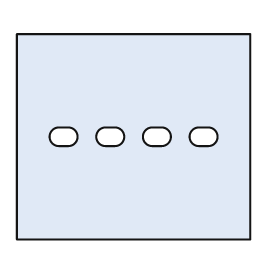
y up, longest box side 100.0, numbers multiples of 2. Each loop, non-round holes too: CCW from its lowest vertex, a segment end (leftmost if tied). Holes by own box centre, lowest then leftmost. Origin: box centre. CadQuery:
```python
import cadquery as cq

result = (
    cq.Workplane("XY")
    .moveTo(-50.0, -44.0)
    .lineTo(50.0, -44.0)
    .lineTo(50.0, 44.0)
    .lineTo(-50.0, 44.0)
    .close()
    .moveTo(-32.0, -4.0)
    .lineTo(-28.0, -4.0)
    .threePointArc((-24.0, 0.0), (-28.0, 4.0))
    .lineTo(-32.0, 4.0)
    .threePointArc((-36.0, 0.0), (-32.0, -4.0))
    .close()
    .moveTo(-12.0, -4.0)
    .lineTo(-8.0, -4.0)
    .threePointArc((-4.0, 0.0), (-8.0, 4.0))
    .lineTo(-12.0, 4.0)
    .threePointArc((-16.0, 0.0), (-12.0, -4.0))
    .close()
    .moveTo(8.0, -4.0)
    .lineTo(12.0, -4.0)
    .threePointArc((16.0, 0.0), (12.0, 4.0))
    .lineTo(8.0, 4.0)
    .threePointArc((4.0, 0.0), (8.0, -4.0))
    .close()
    .moveTo(28.0, -4.0)
    .lineTo(32.0, -4.0)
    .threePointArc((36.0, 0.0), (32.0, 4.0))
    .lineTo(28.0, 4.0)
    .threePointArc((24.0, 0.0), (28.0, -4.0))
    .close()
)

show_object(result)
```